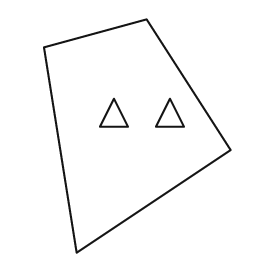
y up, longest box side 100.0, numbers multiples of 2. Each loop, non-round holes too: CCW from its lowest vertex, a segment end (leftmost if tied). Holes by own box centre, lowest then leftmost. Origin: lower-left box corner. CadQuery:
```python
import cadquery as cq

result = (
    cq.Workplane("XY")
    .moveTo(14.0, 0.0)
    .lineTo(80.0, 44.0)
    .lineTo(44.0, 100.0)
    .lineTo(0.0, 88.0)
    .close()
    .moveTo(24.0, 54.0)
    .lineTo(36.0, 54.0)
    .lineTo(30.0, 66.0)
    .close()
    .moveTo(48.0, 54.0)
    .lineTo(60.0, 54.0)
    .lineTo(54.0, 66.0)
    .close()
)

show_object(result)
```